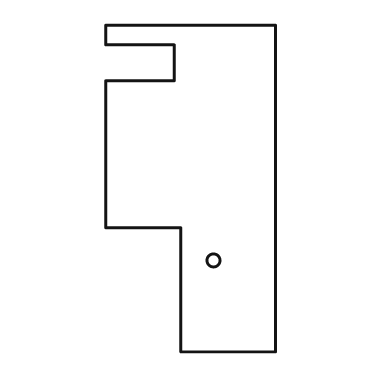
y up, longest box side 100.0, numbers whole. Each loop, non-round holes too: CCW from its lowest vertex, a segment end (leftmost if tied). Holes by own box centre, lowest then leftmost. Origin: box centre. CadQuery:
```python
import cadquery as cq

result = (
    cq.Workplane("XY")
    .moveTo(-3.0, -50.0)
    .lineTo(26.0, -50.0)
    .lineTo(26.0, 50.0)
    .lineTo(-26.0, 50.0)
    .lineTo(-26.0, 44.0)
    .lineTo(-5.0, 44.0)
    .lineTo(-5.0, 33.0)
    .lineTo(-26.0, 33.0)
    .lineTo(-26.0, -12.0)
    .lineTo(-3.0, -12.0)
    .close()
    .moveTo(7.0, -22.0)
    .circle(2.0)
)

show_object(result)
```